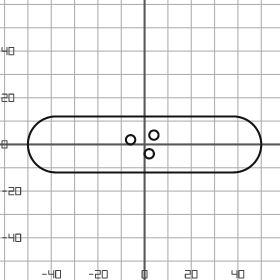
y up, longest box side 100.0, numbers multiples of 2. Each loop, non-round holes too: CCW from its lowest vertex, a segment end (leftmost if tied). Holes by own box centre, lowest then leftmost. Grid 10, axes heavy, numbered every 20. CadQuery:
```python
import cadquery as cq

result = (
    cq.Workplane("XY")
    .moveTo(-38.0, -12.0)
    .lineTo(38.0, -12.0)
    .threePointArc((50.0, 0.0), (38.0, 12.0))
    .lineTo(-38.0, 12.0)
    .threePointArc((-50.0, 0.0), (-38.0, -12.0))
    .close()
    .moveTo(2.0, -4.0)
    .circle(2.0)
    .moveTo(-6.0, 2.0)
    .circle(2.0)
    .moveTo(4.0, 4.0)
    .circle(2.0)
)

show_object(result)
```